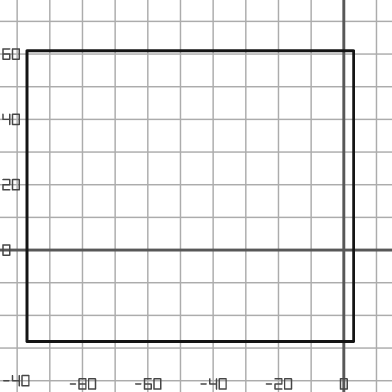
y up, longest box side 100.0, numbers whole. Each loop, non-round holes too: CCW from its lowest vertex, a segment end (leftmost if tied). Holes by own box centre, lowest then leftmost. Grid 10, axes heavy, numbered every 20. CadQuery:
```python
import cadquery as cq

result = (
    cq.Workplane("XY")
    .moveTo(-97.0, -28.0)
    .lineTo(3.0, -28.0)
    .lineTo(3.0, 61.0)
    .lineTo(-97.0, 61.0)
    .close()
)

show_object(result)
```